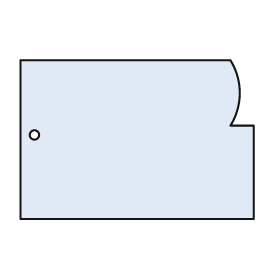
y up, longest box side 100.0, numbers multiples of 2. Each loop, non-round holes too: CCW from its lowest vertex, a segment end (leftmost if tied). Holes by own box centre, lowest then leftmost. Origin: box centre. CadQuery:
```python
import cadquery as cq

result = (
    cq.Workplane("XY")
    .moveTo(-50.0, -34.0)
    .lineTo(50.0, -34.0)
    .lineTo(50.0, 6.0)
    .lineTo(40.0, 6.0)
    .threePointArc((44.0, 20.0), (40.0, 34.0))
    .lineTo(-50.0, 34.0)
    .close()
    .moveTo(-44.0, 2.0)
    .circle(2.0)
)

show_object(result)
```